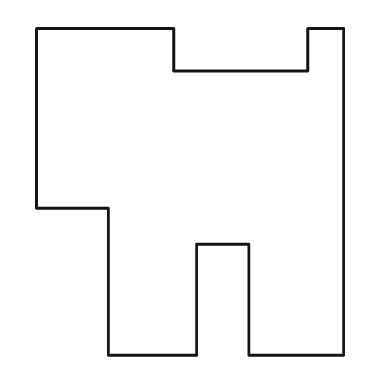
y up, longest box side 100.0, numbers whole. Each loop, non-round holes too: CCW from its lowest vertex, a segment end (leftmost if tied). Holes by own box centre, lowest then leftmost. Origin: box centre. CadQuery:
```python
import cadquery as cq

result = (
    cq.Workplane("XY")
    .moveTo(-25.0, -50.0)
    .lineTo(2.0, -50.0)
    .lineTo(2.0, -16.0)
    .lineTo(18.0, -16.0)
    .lineTo(18.0, -50.0)
    .lineTo(47.0, -50.0)
    .lineTo(47.0, 50.0)
    .lineTo(36.0, 50.0)
    .lineTo(36.0, 37.0)
    .lineTo(-5.0, 37.0)
    .lineTo(-5.0, 50.0)
    .lineTo(-47.0, 50.0)
    .lineTo(-47.0, -5.0)
    .lineTo(-25.0, -5.0)
    .close()
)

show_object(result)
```